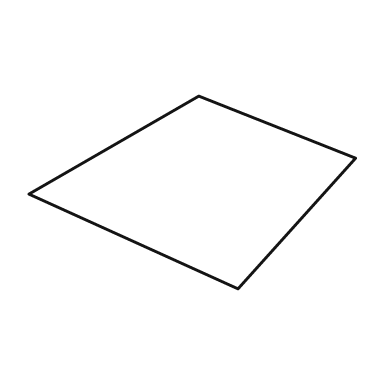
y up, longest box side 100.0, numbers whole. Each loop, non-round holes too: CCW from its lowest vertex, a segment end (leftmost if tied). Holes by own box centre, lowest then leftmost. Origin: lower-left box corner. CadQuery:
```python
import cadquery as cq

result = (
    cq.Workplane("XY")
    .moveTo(64.0, 0.0)
    .lineTo(100.0, 40.0)
    .lineTo(52.0, 59.0)
    .lineTo(0.0, 29.0)
    .close()
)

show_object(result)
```